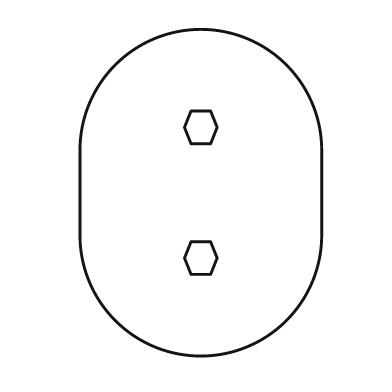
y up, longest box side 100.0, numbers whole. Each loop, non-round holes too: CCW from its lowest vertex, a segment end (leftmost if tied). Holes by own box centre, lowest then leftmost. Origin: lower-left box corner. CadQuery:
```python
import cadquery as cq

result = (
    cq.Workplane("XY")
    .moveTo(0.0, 37.0)
    .threePointArc((37.0, 0.0), (74.0, 37.0))
    .lineTo(74.0, 63.0)
    .threePointArc((37.0, 100.0), (0.0, 63.0))
    .close()
    .moveTo(34.0, 25.0)
    .lineTo(40.0, 25.0)
    .lineTo(42.0, 30.0)
    .lineTo(40.0, 35.0)
    .lineTo(34.0, 35.0)
    .lineTo(32.0, 30.0)
    .close()
    .moveTo(34.0, 65.0)
    .lineTo(40.0, 65.0)
    .lineTo(42.0, 70.0)
    .lineTo(40.0, 75.0)
    .lineTo(34.0, 75.0)
    .lineTo(32.0, 70.0)
    .close()
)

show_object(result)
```